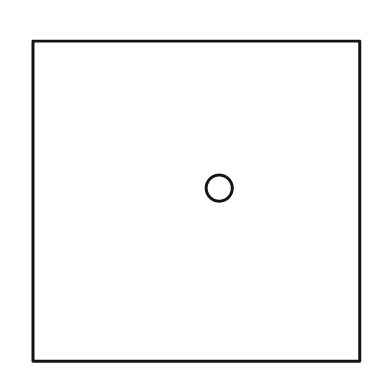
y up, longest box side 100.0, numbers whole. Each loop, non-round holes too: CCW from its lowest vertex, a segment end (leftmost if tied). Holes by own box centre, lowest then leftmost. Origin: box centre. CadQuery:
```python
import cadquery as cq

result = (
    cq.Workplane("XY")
    .moveTo(-50.0, -49.0)
    .lineTo(50.0, -49.0)
    .lineTo(50.0, 49.0)
    .lineTo(-50.0, 49.0)
    .close()
    .moveTo(7.0, 4.0)
    .circle(4.0)
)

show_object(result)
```